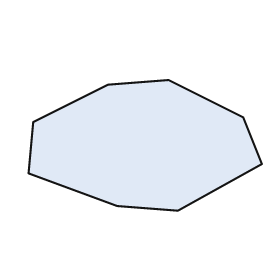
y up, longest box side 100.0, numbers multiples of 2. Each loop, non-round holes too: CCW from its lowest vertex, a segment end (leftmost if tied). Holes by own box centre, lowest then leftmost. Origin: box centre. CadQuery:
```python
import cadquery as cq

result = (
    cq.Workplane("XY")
    .moveTo(14.0, -28.0)
    .lineTo(50.0, -8.0)
    .lineTo(42.0, 12.0)
    .lineTo(10.0, 28.0)
    .lineTo(-16.0, 26.0)
    .lineTo(-48.0, 10.0)
    .lineTo(-50.0, -12.0)
    .lineTo(-12.0, -26.0)
    .close()
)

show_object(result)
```